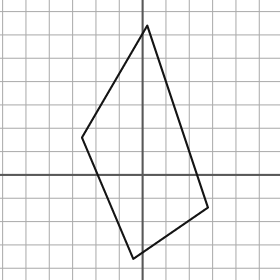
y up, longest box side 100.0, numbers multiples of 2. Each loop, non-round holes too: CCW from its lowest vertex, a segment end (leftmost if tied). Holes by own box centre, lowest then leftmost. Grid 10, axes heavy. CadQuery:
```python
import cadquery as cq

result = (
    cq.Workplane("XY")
    .moveTo(-4.0, -36.0)
    .lineTo(28.0, -14.0)
    .lineTo(2.0, 64.0)
    .lineTo(-26.0, 16.0)
    .close()
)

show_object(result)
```